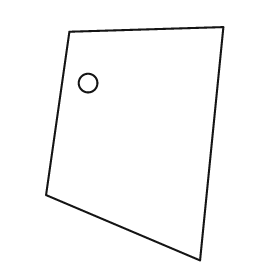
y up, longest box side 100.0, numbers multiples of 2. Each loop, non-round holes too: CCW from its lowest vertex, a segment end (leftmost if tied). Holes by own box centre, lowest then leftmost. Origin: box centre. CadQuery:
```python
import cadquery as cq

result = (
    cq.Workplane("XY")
    .moveTo(28.0, -50.0)
    .lineTo(38.0, 50.0)
    .lineTo(-28.0, 48.0)
    .lineTo(-38.0, -22.0)
    .close()
    .moveTo(-20.0, 26.0)
    .circle(4.0)
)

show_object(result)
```